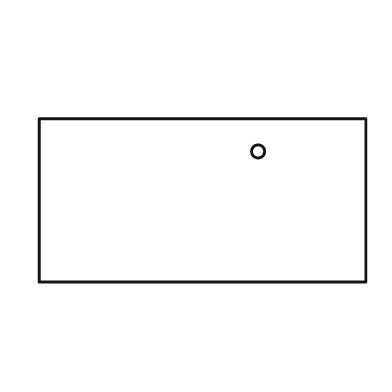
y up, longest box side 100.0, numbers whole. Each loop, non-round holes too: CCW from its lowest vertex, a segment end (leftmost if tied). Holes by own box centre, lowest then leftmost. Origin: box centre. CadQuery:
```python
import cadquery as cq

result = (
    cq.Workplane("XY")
    .moveTo(-50.0, -25.0)
    .lineTo(50.0, -25.0)
    .lineTo(50.0, 25.0)
    .lineTo(-50.0, 25.0)
    .close()
    .moveTo(17.0, 15.0)
    .circle(2.0)
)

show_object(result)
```